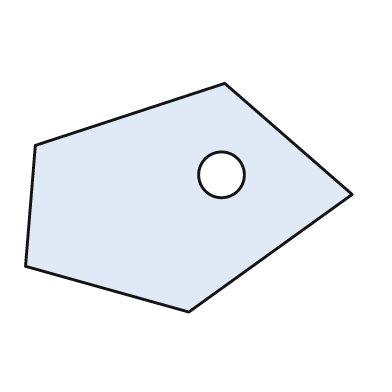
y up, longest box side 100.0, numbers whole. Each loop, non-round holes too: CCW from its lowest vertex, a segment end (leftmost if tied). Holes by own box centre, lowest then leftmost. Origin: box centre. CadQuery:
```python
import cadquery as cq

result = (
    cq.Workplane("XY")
    .moveTo(0.0, -35.0)
    .lineTo(50.0, 1.0)
    .lineTo(11.0, 35.0)
    .lineTo(-47.0, 16.0)
    .lineTo(-50.0, -21.0)
    .close()
    .moveTo(10.0, 7.0)
    .circle(7.0)
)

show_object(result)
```